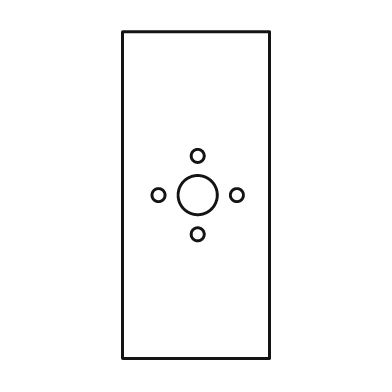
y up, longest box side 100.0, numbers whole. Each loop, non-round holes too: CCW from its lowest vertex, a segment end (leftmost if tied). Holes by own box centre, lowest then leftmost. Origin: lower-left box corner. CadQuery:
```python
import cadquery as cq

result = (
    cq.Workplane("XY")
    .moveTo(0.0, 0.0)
    .lineTo(45.0, 0.0)
    .lineTo(45.0, 100.0)
    .lineTo(0.0, 100.0)
    .close()
    .moveTo(23.0, 38.0)
    .circle(2.0)
    .moveTo(11.0, 50.0)
    .circle(2.0)
    .moveTo(23.0, 50.0)
    .circle(6.0)
    .moveTo(35.0, 50.0)
    .circle(2.0)
    .moveTo(23.0, 62.0)
    .circle(2.0)
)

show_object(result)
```